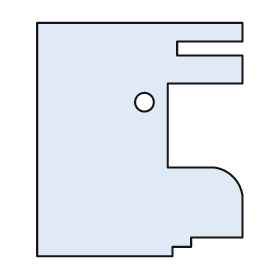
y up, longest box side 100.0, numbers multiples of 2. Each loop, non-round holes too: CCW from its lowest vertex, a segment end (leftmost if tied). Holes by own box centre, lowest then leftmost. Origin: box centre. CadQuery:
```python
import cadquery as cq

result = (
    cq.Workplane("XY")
    .moveTo(-44.0, -50.0)
    .lineTo(14.0, -50.0)
    .lineTo(14.0, -46.0)
    .lineTo(22.0, -46.0)
    .lineTo(22.0, -42.0)
    .lineTo(44.0, -42.0)
    .lineTo(44.0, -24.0)
    .threePointArc((40.0, -16.0), (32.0, -12.0))
    .lineTo(12.0, -12.0)
    .lineTo(12.0, 24.0)
    .lineTo(44.0, 24.0)
    .lineTo(44.0, 36.0)
    .lineTo(16.0, 36.0)
    .lineTo(16.0, 42.0)
    .lineTo(44.0, 42.0)
    .lineTo(44.0, 50.0)
    .lineTo(-44.0, 50.0)
    .close()
    .moveTo(2.0, 16.0)
    .circle(4.0)
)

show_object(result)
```